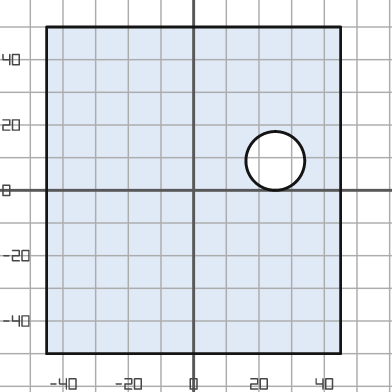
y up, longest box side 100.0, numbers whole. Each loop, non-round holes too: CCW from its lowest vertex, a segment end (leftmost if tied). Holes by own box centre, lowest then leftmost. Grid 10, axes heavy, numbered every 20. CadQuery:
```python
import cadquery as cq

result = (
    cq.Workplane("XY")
    .moveTo(-45.0, -50.0)
    .lineTo(45.0, -50.0)
    .lineTo(45.0, 50.0)
    .lineTo(-45.0, 50.0)
    .close()
    .moveTo(25.0, 9.0)
    .circle(9.0)
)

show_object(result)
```